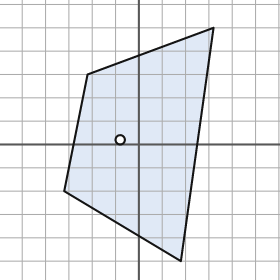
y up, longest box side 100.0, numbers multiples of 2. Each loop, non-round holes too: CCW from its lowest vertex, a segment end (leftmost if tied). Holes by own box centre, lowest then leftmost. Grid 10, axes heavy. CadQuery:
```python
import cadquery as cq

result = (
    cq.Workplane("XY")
    .moveTo(18.0, -50.0)
    .lineTo(32.0, 50.0)
    .lineTo(-22.0, 30.0)
    .lineTo(-32.0, -20.0)
    .close()
    .moveTo(-8.0, 2.0)
    .circle(2.0)
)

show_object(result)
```